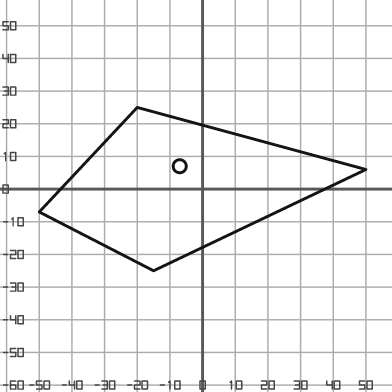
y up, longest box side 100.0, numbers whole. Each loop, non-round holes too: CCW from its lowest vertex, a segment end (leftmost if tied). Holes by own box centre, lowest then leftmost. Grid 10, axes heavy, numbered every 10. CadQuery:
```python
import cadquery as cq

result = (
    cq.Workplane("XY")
    .moveTo(-15.0, -25.0)
    .lineTo(50.0, 6.0)
    .lineTo(-20.0, 25.0)
    .lineTo(-50.0, -7.0)
    .close()
    .moveTo(-7.0, 7.0)
    .circle(2.0)
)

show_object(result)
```